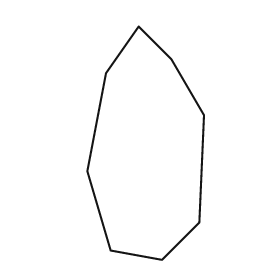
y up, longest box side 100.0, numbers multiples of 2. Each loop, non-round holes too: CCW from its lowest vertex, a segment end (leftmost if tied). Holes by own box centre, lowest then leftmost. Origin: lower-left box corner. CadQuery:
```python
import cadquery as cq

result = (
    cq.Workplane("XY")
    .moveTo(32.0, 0.0)
    .lineTo(48.0, 16.0)
    .lineTo(50.0, 62.0)
    .lineTo(36.0, 86.0)
    .lineTo(22.0, 100.0)
    .lineTo(8.0, 80.0)
    .lineTo(0.0, 38.0)
    .lineTo(10.0, 4.0)
    .close()
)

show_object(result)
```